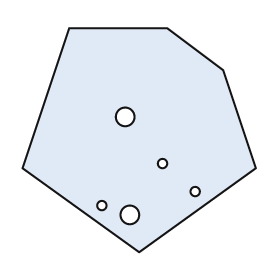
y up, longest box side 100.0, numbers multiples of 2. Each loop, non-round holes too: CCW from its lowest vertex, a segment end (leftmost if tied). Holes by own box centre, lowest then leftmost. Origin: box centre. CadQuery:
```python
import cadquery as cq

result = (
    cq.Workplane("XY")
    .moveTo(0.0, -48.0)
    .lineTo(50.0, -12.0)
    .lineTo(36.0, 30.0)
    .lineTo(12.0, 48.0)
    .lineTo(-30.0, 48.0)
    .lineTo(-50.0, -12.0)
    .close()
    .moveTo(-4.0, -32.0)
    .circle(4.0)
    .moveTo(-16.0, -28.0)
    .circle(2.0)
    .moveTo(24.0, -22.0)
    .circle(2.0)
    .moveTo(10.0, -10.0)
    .circle(2.0)
    .moveTo(-6.0, 10.0)
    .circle(4.0)
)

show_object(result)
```